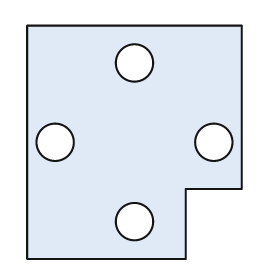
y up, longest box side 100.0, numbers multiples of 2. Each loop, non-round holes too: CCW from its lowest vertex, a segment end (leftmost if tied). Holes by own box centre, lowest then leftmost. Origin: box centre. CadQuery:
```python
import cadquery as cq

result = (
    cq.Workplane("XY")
    .moveTo(-46.0, -50.0)
    .lineTo(22.0, -50.0)
    .lineTo(22.0, -20.0)
    .lineTo(46.0, -20.0)
    .lineTo(46.0, 50.0)
    .lineTo(-46.0, 50.0)
    .close()
    .moveTo(0.0, -34.0)
    .circle(8.0)
    .moveTo(-34.0, 0.0)
    .circle(8.0)
    .moveTo(34.0, 0.0)
    .circle(8.0)
    .moveTo(0.0, 34.0)
    .circle(8.0)
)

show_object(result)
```